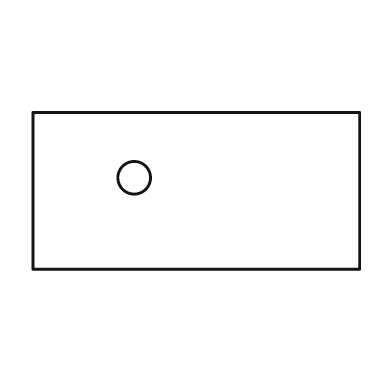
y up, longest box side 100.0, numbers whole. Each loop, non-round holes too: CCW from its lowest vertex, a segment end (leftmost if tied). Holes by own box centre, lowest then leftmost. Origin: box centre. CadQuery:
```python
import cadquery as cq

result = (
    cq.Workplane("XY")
    .moveTo(-50.0, -24.0)
    .lineTo(50.0, -24.0)
    .lineTo(50.0, 24.0)
    .lineTo(-50.0, 24.0)
    .close()
    .moveTo(-19.0, 4.0)
    .circle(5.0)
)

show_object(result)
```